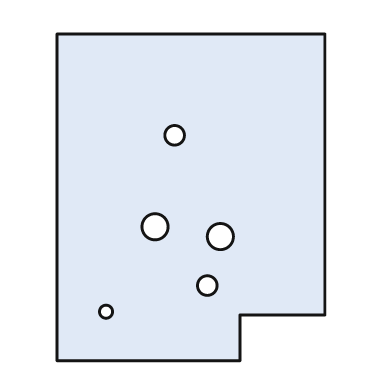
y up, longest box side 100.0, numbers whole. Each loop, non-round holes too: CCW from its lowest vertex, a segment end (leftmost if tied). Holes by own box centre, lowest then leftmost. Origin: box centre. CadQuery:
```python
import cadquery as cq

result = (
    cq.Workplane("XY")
    .moveTo(-41.0, -50.0)
    .lineTo(15.0, -50.0)
    .lineTo(15.0, -36.0)
    .lineTo(41.0, -36.0)
    .lineTo(41.0, 50.0)
    .lineTo(-41.0, 50.0)
    .close()
    .moveTo(-26.0, -35.0)
    .circle(2.0)
    .moveTo(5.0, -27.0)
    .circle(3.0)
    .moveTo(9.0, -12.0)
    .circle(4.0)
    .moveTo(-11.0, -9.0)
    .circle(4.0)
    .moveTo(-5.0, 19.0)
    .circle(3.0)
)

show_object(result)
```